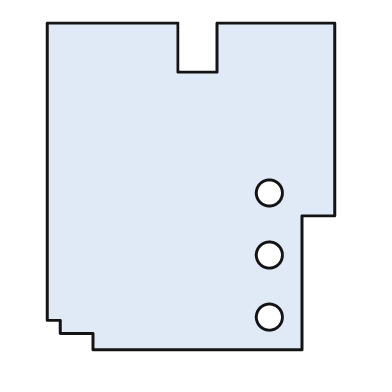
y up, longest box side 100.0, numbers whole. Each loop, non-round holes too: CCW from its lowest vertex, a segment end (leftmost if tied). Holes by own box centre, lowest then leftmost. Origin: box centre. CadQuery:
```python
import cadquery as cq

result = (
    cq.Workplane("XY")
    .moveTo(-30.0, -50.0)
    .lineTo(34.0, -50.0)
    .lineTo(34.0, -9.0)
    .lineTo(44.0, -9.0)
    .lineTo(44.0, 50.0)
    .lineTo(8.0, 50.0)
    .lineTo(8.0, 35.0)
    .lineTo(-4.0, 35.0)
    .lineTo(-4.0, 50.0)
    .lineTo(-44.0, 50.0)
    .lineTo(-44.0, -41.0)
    .lineTo(-40.0, -41.0)
    .lineTo(-40.0, -45.0)
    .lineTo(-30.0, -45.0)
    .close()
    .moveTo(24.0, -40.0)
    .circle(4.0)
    .moveTo(24.0, -21.0)
    .circle(4.0)
    .moveTo(24.0, -2.0)
    .circle(4.0)
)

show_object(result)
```